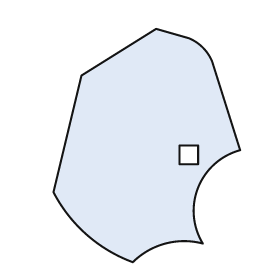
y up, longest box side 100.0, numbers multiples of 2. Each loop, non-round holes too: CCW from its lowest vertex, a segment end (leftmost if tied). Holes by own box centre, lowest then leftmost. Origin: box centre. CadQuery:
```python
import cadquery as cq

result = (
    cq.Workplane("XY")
    .moveTo(-6.0, -50.0)
    .threePointArc((8.0, -42.0), (24.0, -42.0))
    .threePointArc((22.0, -18.0), (40.0, -2.0))
    .lineTo(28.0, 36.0)
    .threePointArc((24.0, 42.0), (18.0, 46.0))
    .lineTo(4.0, 50.0)
    .lineTo(-28.0, 30.0)
    .lineTo(-40.0, -20.0)
    .threePointArc((-26.0, -38.0), (-6.0, -50.0))
    .close()
    .moveTo(14.0, -8.0)
    .lineTo(22.0, -8.0)
    .lineTo(22.0, 0.0)
    .lineTo(14.0, 0.0)
    .close()
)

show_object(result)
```